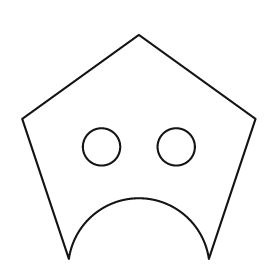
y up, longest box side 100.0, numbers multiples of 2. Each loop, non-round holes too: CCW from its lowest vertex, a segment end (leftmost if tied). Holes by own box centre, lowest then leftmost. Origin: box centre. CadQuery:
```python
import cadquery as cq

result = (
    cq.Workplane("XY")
    .moveTo(-30.0, -48.0)
    .threePointArc((0.0, -22.0), (30.0, -48.0))
    .lineTo(50.0, 12.0)
    .lineTo(0.0, 48.0)
    .lineTo(-50.0, 12.0)
    .close()
    .moveTo(-16.0, 0.0)
    .circle(8.0)
    .moveTo(16.0, 0.0)
    .circle(8.0)
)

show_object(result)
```